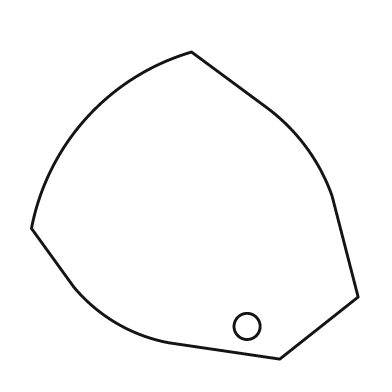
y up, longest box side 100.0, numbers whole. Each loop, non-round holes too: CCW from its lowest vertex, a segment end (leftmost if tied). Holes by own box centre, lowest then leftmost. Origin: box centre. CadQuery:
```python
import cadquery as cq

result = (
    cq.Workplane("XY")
    .moveTo(26.0, -47.0)
    .lineTo(50.0, -28.0)
    .lineTo(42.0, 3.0)
    .threePointArc((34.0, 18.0), (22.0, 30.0))
    .lineTo(-1.0, 47.0)
    .threePointArc((-33.0, 27.0), (-50.0, -7.0))
    .lineTo(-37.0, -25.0)
    .threePointArc((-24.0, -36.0), (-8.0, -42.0))
    .close()
    .moveTo(16.0, -37.0)
    .circle(4.0)
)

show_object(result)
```